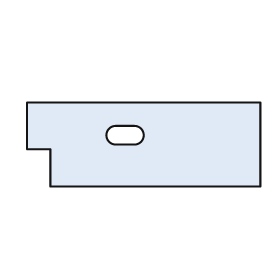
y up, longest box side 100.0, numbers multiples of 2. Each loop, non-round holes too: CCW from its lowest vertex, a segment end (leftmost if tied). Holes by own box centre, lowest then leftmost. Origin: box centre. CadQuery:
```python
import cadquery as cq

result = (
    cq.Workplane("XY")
    .moveTo(-40.0, -18.0)
    .lineTo(50.0, -18.0)
    .lineTo(50.0, 18.0)
    .lineTo(-50.0, 18.0)
    .lineTo(-50.0, -2.0)
    .lineTo(-40.0, -2.0)
    .close()
    .moveTo(-12.0, 0.0)
    .lineTo(-4.0, 0.0)
    .threePointArc((0.0, 4.0), (-4.0, 8.0))
    .lineTo(-12.0, 8.0)
    .threePointArc((-16.0, 4.0), (-12.0, 0.0))
    .close()
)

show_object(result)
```